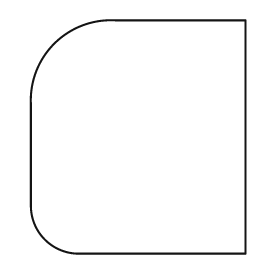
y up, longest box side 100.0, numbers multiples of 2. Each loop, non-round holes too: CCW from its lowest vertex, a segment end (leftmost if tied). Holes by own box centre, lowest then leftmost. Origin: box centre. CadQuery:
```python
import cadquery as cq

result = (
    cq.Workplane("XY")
    .moveTo(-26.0, -50.0)
    .lineTo(46.0, -50.0)
    .lineTo(46.0, 50.0)
    .lineTo(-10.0, 50.0)
    .threePointArc((-36.0, 40.0), (-46.0, 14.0))
    .lineTo(-46.0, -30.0)
    .threePointArc((-40.0, -44.0), (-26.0, -50.0))
    .close()
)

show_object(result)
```